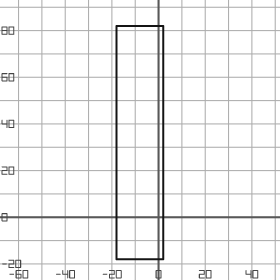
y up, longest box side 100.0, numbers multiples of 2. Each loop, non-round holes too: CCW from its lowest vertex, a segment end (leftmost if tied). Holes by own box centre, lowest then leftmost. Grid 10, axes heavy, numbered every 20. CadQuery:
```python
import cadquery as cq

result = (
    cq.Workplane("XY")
    .moveTo(-18.0, -18.0)
    .lineTo(2.0, -18.0)
    .lineTo(2.0, 82.0)
    .lineTo(-18.0, 82.0)
    .close()
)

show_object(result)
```